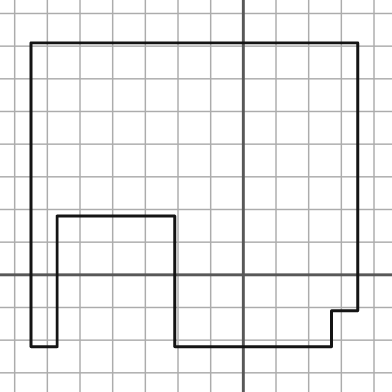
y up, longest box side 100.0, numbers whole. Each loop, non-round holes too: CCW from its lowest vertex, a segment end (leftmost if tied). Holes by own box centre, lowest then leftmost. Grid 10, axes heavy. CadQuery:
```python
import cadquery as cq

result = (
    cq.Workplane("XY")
    .moveTo(-65.0, -22.0)
    .lineTo(-57.0, -22.0)
    .lineTo(-57.0, 18.0)
    .lineTo(-21.0, 18.0)
    .lineTo(-21.0, -22.0)
    .lineTo(27.0, -22.0)
    .lineTo(27.0, -11.0)
    .lineTo(35.0, -11.0)
    .lineTo(35.0, 71.0)
    .lineTo(-65.0, 71.0)
    .close()
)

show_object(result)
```